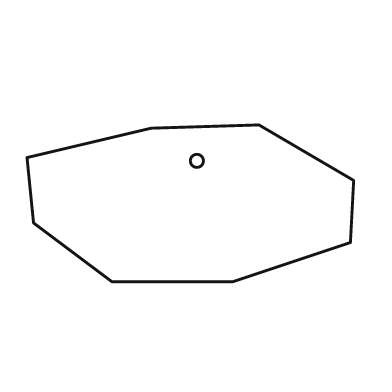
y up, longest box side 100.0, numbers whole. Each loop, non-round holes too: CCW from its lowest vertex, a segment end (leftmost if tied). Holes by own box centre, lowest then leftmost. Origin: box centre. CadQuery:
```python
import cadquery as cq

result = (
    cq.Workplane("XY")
    .moveTo(-24.0, -24.0)
    .lineTo(13.0, -24.0)
    .lineTo(49.0, -12.0)
    .lineTo(50.0, 7.0)
    .lineTo(21.0, 24.0)
    .lineTo(-12.0, 23.0)
    .lineTo(-50.0, 14.0)
    .lineTo(-48.0, -6.0)
    .close()
    .moveTo(2.0, 13.0)
    .circle(2.0)
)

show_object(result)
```